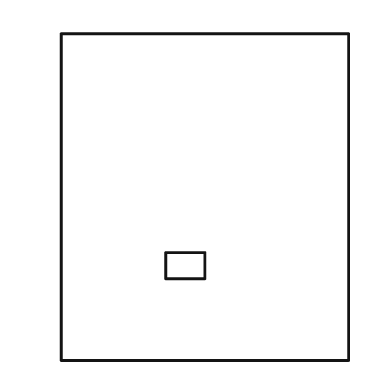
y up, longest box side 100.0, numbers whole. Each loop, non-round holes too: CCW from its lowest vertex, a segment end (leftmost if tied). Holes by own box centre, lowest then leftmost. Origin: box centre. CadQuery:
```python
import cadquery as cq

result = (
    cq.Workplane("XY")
    .moveTo(-44.0, -50.0)
    .lineTo(44.0, -50.0)
    .lineTo(44.0, 50.0)
    .lineTo(-44.0, 50.0)
    .close()
    .moveTo(-12.0, -25.0)
    .lineTo(0.0, -25.0)
    .lineTo(0.0, -17.0)
    .lineTo(-12.0, -17.0)
    .close()
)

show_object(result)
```